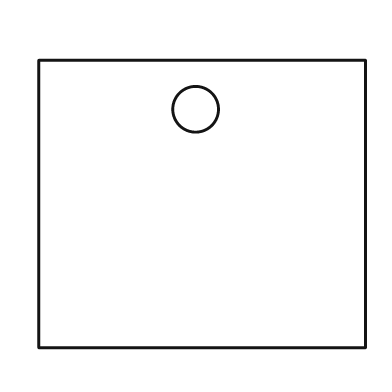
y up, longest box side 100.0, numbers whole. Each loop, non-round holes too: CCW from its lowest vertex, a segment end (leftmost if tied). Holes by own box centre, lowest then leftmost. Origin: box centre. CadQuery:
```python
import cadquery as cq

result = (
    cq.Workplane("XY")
    .moveTo(-50.0, -44.0)
    .lineTo(50.0, -44.0)
    .lineTo(50.0, 44.0)
    .lineTo(-50.0, 44.0)
    .close()
    .moveTo(-2.0, 29.0)
    .circle(7.0)
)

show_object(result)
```